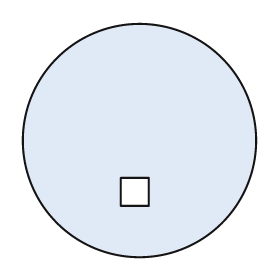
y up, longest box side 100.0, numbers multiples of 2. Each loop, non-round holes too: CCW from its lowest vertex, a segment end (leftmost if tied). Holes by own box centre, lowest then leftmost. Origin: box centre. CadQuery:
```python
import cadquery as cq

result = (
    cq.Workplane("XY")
    .moveTo(0.0, 0.0)
    .circle(50.0)
    .moveTo(-8.0, -28.0)
    .lineTo(4.0, -28.0)
    .lineTo(4.0, -16.0)
    .lineTo(-8.0, -16.0)
    .close()
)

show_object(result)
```